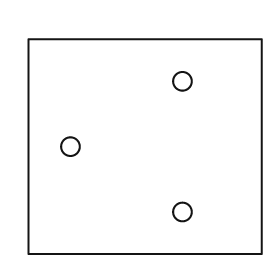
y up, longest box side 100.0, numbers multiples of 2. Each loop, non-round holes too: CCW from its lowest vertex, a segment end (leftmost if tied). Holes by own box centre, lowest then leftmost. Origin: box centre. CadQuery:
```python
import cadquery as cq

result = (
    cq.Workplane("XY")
    .moveTo(-50.0, -46.0)
    .lineTo(50.0, -46.0)
    .lineTo(50.0, 46.0)
    .lineTo(-50.0, 46.0)
    .close()
    .moveTo(16.0, -28.0)
    .circle(4.0)
    .moveTo(-32.0, 0.0)
    .circle(4.0)
    .moveTo(16.0, 28.0)
    .circle(4.0)
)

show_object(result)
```